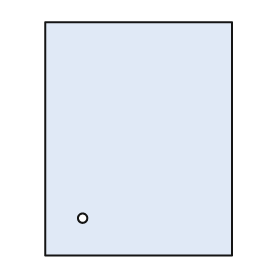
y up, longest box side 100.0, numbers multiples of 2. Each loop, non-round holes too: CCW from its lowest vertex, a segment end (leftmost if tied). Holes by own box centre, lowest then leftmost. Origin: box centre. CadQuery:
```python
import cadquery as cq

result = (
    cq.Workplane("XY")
    .moveTo(-40.0, -50.0)
    .lineTo(40.0, -50.0)
    .lineTo(40.0, 50.0)
    .lineTo(-40.0, 50.0)
    .close()
    .moveTo(-24.0, -34.0)
    .circle(2.0)
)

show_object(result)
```